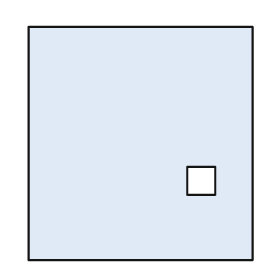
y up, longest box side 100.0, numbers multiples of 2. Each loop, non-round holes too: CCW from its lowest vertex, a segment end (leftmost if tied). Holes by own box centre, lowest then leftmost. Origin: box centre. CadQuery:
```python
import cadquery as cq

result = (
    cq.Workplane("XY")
    .moveTo(-48.0, -50.0)
    .lineTo(48.0, -50.0)
    .lineTo(48.0, 50.0)
    .lineTo(-48.0, 50.0)
    .close()
    .moveTo(20.0, -22.0)
    .lineTo(32.0, -22.0)
    .lineTo(32.0, -10.0)
    .lineTo(20.0, -10.0)
    .close()
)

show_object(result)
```